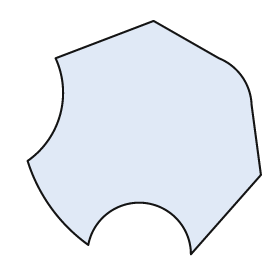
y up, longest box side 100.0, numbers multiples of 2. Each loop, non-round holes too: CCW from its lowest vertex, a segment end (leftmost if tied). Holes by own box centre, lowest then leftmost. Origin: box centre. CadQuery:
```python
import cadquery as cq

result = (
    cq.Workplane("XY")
    .moveTo(20.0, -50.0)
    .lineTo(50.0, -16.0)
    .lineTo(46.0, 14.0)
    .threePointArc((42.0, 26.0), (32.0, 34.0))
    .lineTo(4.0, 50.0)
    .lineTo(-38.0, 34.0)
    .threePointArc((-36.0, 10.0), (-50.0, -10.0))
    .threePointArc((-40.0, -30.0), (-24.0, -46.0))
    .threePointArc((0.0, -28.0), (20.0, -50.0))
    .close()
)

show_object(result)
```